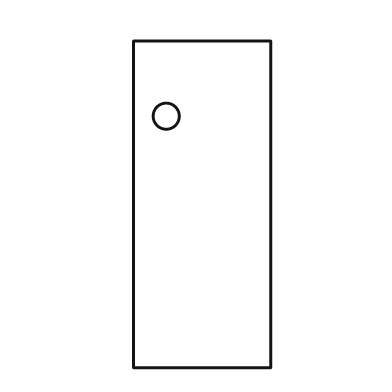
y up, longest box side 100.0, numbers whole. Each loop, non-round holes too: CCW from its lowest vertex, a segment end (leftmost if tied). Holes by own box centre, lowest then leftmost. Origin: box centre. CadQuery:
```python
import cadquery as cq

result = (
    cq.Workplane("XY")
    .moveTo(-21.0, -50.0)
    .lineTo(21.0, -50.0)
    .lineTo(21.0, 50.0)
    .lineTo(-21.0, 50.0)
    .close()
    .moveTo(-11.0, 27.0)
    .circle(4.0)
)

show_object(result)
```